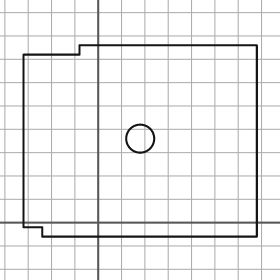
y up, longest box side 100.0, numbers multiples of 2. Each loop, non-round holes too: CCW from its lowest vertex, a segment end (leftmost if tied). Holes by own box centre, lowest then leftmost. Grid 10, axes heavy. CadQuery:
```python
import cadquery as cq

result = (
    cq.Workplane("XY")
    .moveTo(-24.0, -6.0)
    .lineTo(68.0, -6.0)
    .lineTo(68.0, 76.0)
    .lineTo(-8.0, 76.0)
    .lineTo(-8.0, 72.0)
    .lineTo(-32.0, 72.0)
    .lineTo(-32.0, -2.0)
    .lineTo(-24.0, -2.0)
    .close()
    .moveTo(18.0, 36.0)
    .circle(6.0)
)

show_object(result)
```